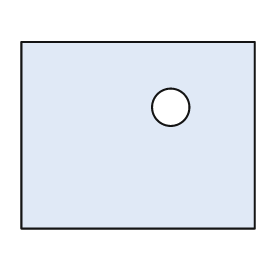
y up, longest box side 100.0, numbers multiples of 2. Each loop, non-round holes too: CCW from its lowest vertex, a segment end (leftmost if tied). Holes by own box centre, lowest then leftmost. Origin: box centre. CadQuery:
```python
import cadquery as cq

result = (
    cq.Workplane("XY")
    .moveTo(-50.0, -40.0)
    .lineTo(50.0, -40.0)
    .lineTo(50.0, 40.0)
    .lineTo(-50.0, 40.0)
    .close()
    .moveTo(14.0, 12.0)
    .circle(8.0)
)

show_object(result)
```